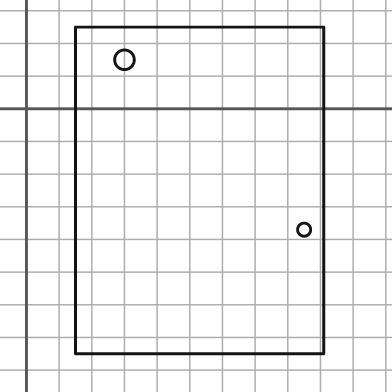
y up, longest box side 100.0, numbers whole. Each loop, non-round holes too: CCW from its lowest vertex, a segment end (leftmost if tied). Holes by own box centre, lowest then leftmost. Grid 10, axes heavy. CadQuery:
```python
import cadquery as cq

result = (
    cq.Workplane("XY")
    .moveTo(15.0, -75.0)
    .lineTo(91.0, -75.0)
    .lineTo(91.0, 25.0)
    .lineTo(15.0, 25.0)
    .close()
    .moveTo(85.0, -37.0)
    .circle(2.0)
    .moveTo(30.0, 15.0)
    .circle(3.0)
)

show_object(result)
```